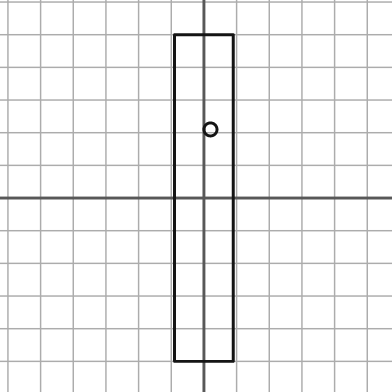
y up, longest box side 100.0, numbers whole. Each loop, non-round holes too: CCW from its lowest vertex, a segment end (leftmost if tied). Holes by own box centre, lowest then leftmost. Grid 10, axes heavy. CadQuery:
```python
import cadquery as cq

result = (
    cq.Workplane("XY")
    .moveTo(-9.0, -50.0)
    .lineTo(9.0, -50.0)
    .lineTo(9.0, 50.0)
    .lineTo(-9.0, 50.0)
    .close()
    .moveTo(2.0, 21.0)
    .circle(2.0)
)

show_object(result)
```